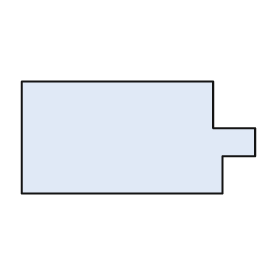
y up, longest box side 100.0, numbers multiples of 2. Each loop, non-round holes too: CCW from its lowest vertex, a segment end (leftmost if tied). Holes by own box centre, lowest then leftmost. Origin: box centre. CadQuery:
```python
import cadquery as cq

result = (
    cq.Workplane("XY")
    .moveTo(-50.0, -24.0)
    .lineTo(36.0, -24.0)
    .lineTo(36.0, -8.0)
    .lineTo(50.0, -8.0)
    .lineTo(50.0, 4.0)
    .lineTo(32.0, 4.0)
    .lineTo(32.0, 24.0)
    .lineTo(-50.0, 24.0)
    .close()
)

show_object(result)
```